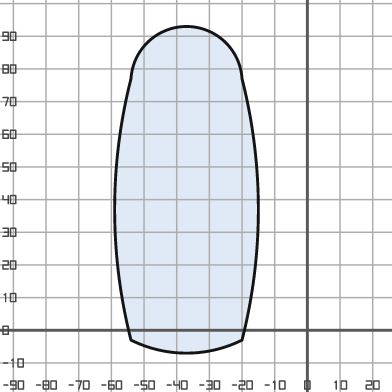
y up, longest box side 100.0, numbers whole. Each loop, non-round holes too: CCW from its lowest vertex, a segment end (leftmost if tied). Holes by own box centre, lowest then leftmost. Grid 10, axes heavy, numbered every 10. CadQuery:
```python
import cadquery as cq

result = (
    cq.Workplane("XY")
    .moveTo(-54.0, -3.0)
    .threePointArc((-37.0, -7.0), (-20.0, -3.0))
    .threePointArc((-15.0, 37.0), (-20.0, 77.0))
    .threePointArc((-37.0, 93.0), (-54.0, 77.0))
    .threePointArc((-59.0, 37.0), (-54.0, -3.0))
    .close()
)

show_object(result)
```